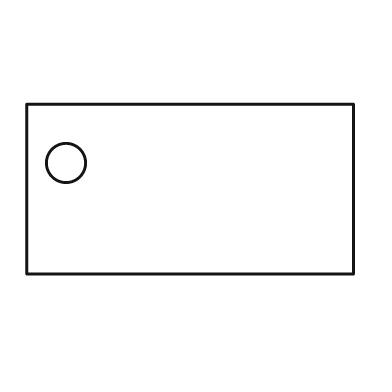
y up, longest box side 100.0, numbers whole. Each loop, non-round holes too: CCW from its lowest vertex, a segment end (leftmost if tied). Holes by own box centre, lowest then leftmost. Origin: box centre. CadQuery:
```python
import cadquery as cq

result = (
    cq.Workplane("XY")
    .moveTo(-50.0, -26.0)
    .lineTo(50.0, -26.0)
    .lineTo(50.0, 26.0)
    .lineTo(-50.0, 26.0)
    .close()
    .moveTo(-38.0, 8.0)
    .circle(6.0)
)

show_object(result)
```